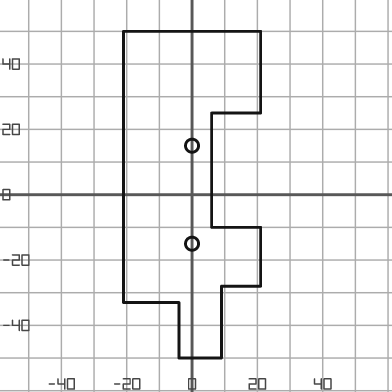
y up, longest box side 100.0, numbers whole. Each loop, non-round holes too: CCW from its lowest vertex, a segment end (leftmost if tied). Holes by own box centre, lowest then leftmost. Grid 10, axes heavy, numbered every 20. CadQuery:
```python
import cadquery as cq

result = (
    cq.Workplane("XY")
    .moveTo(-4.0, -50.0)
    .lineTo(9.0, -50.0)
    .lineTo(9.0, -28.0)
    .lineTo(21.0, -28.0)
    .lineTo(21.0, -10.0)
    .lineTo(6.0, -10.0)
    .lineTo(6.0, 25.0)
    .lineTo(21.0, 25.0)
    .lineTo(21.0, 50.0)
    .lineTo(-21.0, 50.0)
    .lineTo(-21.0, -33.0)
    .lineTo(-4.0, -33.0)
    .close()
    .moveTo(0.0, -15.0)
    .circle(2.0)
    .moveTo(0.0, 15.0)
    .circle(2.0)
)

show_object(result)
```